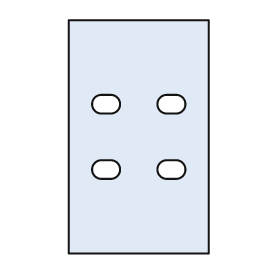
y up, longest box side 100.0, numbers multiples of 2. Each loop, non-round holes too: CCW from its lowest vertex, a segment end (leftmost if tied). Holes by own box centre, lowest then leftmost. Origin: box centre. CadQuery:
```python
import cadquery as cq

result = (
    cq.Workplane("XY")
    .moveTo(-30.0, -50.0)
    .lineTo(30.0, -50.0)
    .lineTo(30.0, 50.0)
    .lineTo(-30.0, 50.0)
    .close()
    .moveTo(-16.0, -18.0)
    .lineTo(-12.0, -18.0)
    .threePointArc((-8.0, -14.0), (-12.0, -10.0))
    .lineTo(-16.0, -10.0)
    .threePointArc((-20.0, -14.0), (-16.0, -18.0))
    .close()
    .moveTo(12.0, -18.0)
    .lineTo(16.0, -18.0)
    .threePointArc((20.0, -14.0), (16.0, -10.0))
    .lineTo(12.0, -10.0)
    .threePointArc((8.0, -14.0), (12.0, -18.0))
    .close()
    .moveTo(-16.0, 10.0)
    .lineTo(-12.0, 10.0)
    .threePointArc((-8.0, 14.0), (-12.0, 18.0))
    .lineTo(-16.0, 18.0)
    .threePointArc((-20.0, 14.0), (-16.0, 10.0))
    .close()
    .moveTo(12.0, 10.0)
    .lineTo(16.0, 10.0)
    .threePointArc((20.0, 14.0), (16.0, 18.0))
    .lineTo(12.0, 18.0)
    .threePointArc((8.0, 14.0), (12.0, 10.0))
    .close()
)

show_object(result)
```